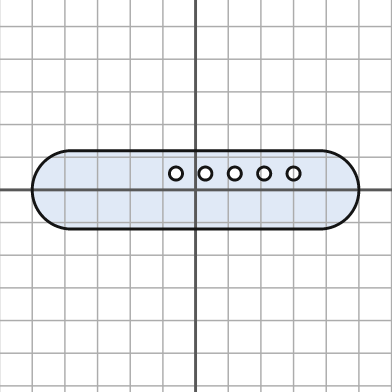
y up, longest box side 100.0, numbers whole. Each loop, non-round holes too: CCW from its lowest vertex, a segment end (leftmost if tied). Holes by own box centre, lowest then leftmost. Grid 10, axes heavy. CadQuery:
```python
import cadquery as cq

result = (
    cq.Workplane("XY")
    .moveTo(-38.0, -12.0)
    .lineTo(38.0, -12.0)
    .threePointArc((50.0, 0.0), (38.0, 12.0))
    .lineTo(-38.0, 12.0)
    .threePointArc((-50.0, 0.0), (-38.0, -12.0))
    .close()
    .moveTo(-6.0, 5.0)
    .circle(2.0)
    .moveTo(3.0, 5.0)
    .circle(2.0)
    .moveTo(12.0, 5.0)
    .circle(2.0)
    .moveTo(21.0, 5.0)
    .circle(2.0)
    .moveTo(30.0, 5.0)
    .circle(2.0)
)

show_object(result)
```